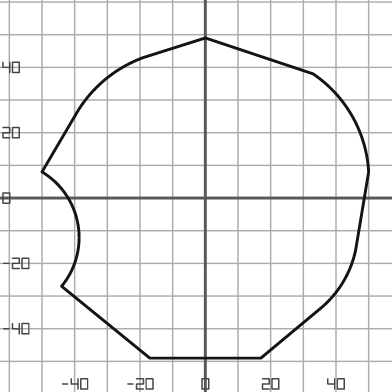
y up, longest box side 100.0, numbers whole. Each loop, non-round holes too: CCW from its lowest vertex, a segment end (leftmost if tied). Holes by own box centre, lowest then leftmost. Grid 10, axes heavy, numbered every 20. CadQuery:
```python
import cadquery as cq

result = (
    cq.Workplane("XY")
    .moveTo(-17.0, -49.0)
    .lineTo(17.0, -49.0)
    .lineTo(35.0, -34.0)
    .threePointArc((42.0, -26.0), (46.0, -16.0))
    .lineTo(50.0, 8.0)
    .threePointArc((45.0, 25.0), (33.0, 38.0))
    .lineTo(0.0, 49.0)
    .lineTo(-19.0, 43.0)
    .threePointArc((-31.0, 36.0), (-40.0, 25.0))
    .lineTo(-50.0, 8.0)
    .threePointArc((-39.0, -8.0), (-44.0, -27.0))
    .close()
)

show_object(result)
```